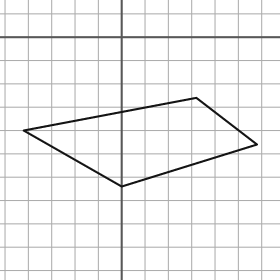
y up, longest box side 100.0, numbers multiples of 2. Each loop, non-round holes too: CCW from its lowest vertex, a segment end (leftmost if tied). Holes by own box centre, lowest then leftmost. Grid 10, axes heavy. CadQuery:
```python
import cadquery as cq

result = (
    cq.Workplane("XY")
    .moveTo(0.0, -64.0)
    .lineTo(58.0, -46.0)
    .lineTo(32.0, -26.0)
    .lineTo(-42.0, -40.0)
    .close()
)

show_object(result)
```